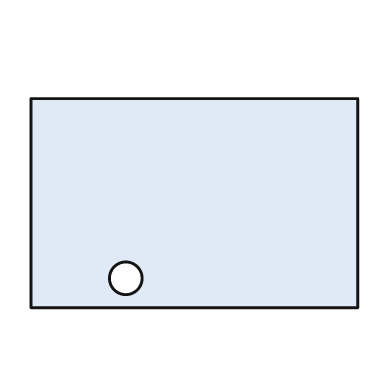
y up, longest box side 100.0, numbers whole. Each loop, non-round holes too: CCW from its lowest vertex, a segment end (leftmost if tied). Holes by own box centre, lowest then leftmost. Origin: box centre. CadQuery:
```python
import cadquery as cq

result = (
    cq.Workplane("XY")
    .moveTo(-50.0, -32.0)
    .lineTo(50.0, -32.0)
    .lineTo(50.0, 32.0)
    .lineTo(-50.0, 32.0)
    .close()
    .moveTo(-21.0, -23.0)
    .circle(5.0)
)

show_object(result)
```